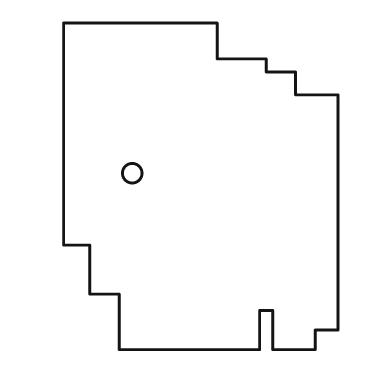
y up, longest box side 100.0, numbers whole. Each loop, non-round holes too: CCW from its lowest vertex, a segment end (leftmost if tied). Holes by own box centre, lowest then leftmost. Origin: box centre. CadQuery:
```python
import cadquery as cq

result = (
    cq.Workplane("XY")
    .moveTo(-25.0, -50.0)
    .lineTo(18.0, -50.0)
    .lineTo(18.0, -38.0)
    .lineTo(22.0, -38.0)
    .lineTo(22.0, -50.0)
    .lineTo(35.0, -50.0)
    .lineTo(35.0, -44.0)
    .lineTo(42.0, -44.0)
    .lineTo(42.0, 28.0)
    .lineTo(29.0, 28.0)
    .lineTo(29.0, 35.0)
    .lineTo(20.0, 35.0)
    .lineTo(20.0, 39.0)
    .lineTo(5.0, 39.0)
    .lineTo(5.0, 50.0)
    .lineTo(-42.0, 50.0)
    .lineTo(-42.0, -18.0)
    .lineTo(-34.0, -18.0)
    .lineTo(-34.0, -33.0)
    .lineTo(-25.0, -33.0)
    .close()
    .moveTo(-21.0, 4.0)
    .circle(3.0)
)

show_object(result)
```